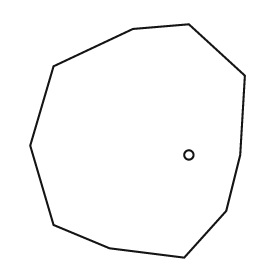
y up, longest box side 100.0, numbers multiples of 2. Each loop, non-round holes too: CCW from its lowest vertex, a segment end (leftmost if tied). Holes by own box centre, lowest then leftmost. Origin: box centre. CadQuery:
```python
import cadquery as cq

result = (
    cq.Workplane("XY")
    .moveTo(20.0, -50.0)
    .lineTo(38.0, -30.0)
    .lineTo(44.0, -6.0)
    .lineTo(46.0, 28.0)
    .lineTo(22.0, 50.0)
    .lineTo(-2.0, 48.0)
    .lineTo(-36.0, 32.0)
    .lineTo(-46.0, -2.0)
    .lineTo(-36.0, -36.0)
    .lineTo(-12.0, -46.0)
    .close()
    .moveTo(22.0, -6.0)
    .circle(2.0)
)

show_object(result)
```